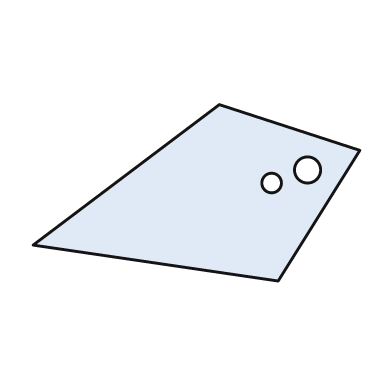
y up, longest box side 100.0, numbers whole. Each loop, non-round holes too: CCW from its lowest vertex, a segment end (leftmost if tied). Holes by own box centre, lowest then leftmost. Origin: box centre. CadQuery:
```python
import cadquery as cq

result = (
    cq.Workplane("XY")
    .moveTo(25.0, -27.0)
    .lineTo(50.0, 13.0)
    .lineTo(7.0, 27.0)
    .lineTo(-50.0, -16.0)
    .close()
    .moveTo(23.0, 3.0)
    .circle(3.0)
    .moveTo(34.0, 7.0)
    .circle(4.0)
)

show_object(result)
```